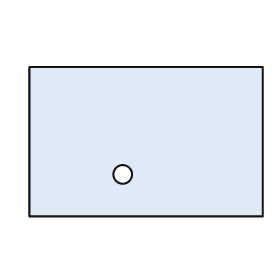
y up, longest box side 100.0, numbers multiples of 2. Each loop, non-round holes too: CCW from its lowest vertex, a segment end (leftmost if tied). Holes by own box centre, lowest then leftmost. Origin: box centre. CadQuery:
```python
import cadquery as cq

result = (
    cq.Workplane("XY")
    .moveTo(-50.0, -32.0)
    .lineTo(50.0, -32.0)
    .lineTo(50.0, 32.0)
    .lineTo(-50.0, 32.0)
    .close()
    .moveTo(-10.0, -14.0)
    .circle(4.0)
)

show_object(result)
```